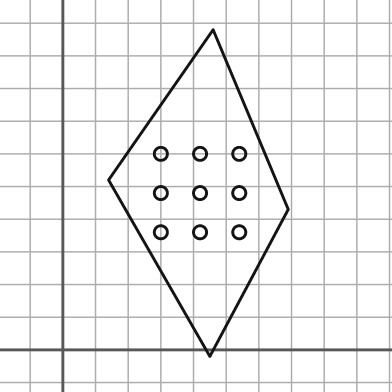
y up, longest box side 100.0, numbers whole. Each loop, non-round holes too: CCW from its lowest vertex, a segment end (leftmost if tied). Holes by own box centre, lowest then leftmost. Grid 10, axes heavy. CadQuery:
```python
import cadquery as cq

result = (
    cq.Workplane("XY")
    .moveTo(45.0, -2.0)
    .lineTo(69.0, 43.0)
    .lineTo(46.0, 98.0)
    .lineTo(14.0, 52.0)
    .close()
    .moveTo(30.0, 36.0)
    .circle(2.0)
    .moveTo(42.0, 36.0)
    .circle(2.0)
    .moveTo(54.0, 36.0)
    .circle(2.0)
    .moveTo(30.0, 48.0)
    .circle(2.0)
    .moveTo(42.0, 48.0)
    .circle(2.0)
    .moveTo(54.0, 48.0)
    .circle(2.0)
    .moveTo(30.0, 60.0)
    .circle(2.0)
    .moveTo(42.0, 60.0)
    .circle(2.0)
    .moveTo(54.0, 60.0)
    .circle(2.0)
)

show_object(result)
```